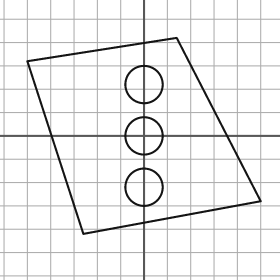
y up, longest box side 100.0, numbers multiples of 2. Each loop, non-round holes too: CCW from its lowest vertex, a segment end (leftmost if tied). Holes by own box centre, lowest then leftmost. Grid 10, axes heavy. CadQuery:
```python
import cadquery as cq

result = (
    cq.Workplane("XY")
    .moveTo(-26.0, -42.0)
    .lineTo(50.0, -28.0)
    .lineTo(14.0, 42.0)
    .lineTo(-50.0, 32.0)
    .close()
    .moveTo(0.0, -22.0)
    .circle(8.0)
    .moveTo(0.0, 0.0)
    .circle(8.0)
    .moveTo(0.0, 22.0)
    .circle(8.0)
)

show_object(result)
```